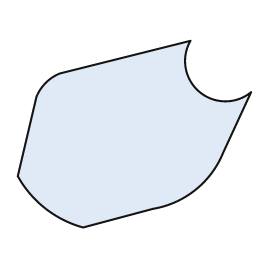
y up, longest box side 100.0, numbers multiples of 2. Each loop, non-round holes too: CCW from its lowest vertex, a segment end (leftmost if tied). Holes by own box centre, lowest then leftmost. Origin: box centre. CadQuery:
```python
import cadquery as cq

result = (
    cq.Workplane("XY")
    .moveTo(-22.0, -40.0)
    .lineTo(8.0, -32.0)
    .threePointArc((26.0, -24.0), (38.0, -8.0))
    .lineTo(50.0, 18.0)
    .threePointArc((28.0, 18.0), (24.0, 40.0))
    .lineTo(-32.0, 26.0)
    .threePointArc((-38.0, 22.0), (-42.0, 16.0))
    .lineTo(-50.0, -18.0)
    .threePointArc((-38.0, -32.0), (-22.0, -40.0))
    .close()
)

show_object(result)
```